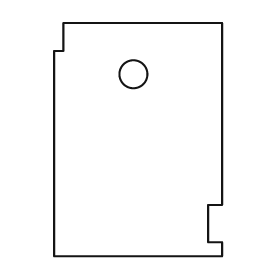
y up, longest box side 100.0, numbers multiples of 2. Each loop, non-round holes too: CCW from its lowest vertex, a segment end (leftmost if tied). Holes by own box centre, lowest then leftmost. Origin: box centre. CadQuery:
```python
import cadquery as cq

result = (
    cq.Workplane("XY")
    .moveTo(-36.0, -50.0)
    .lineTo(36.0, -50.0)
    .lineTo(36.0, -44.0)
    .lineTo(30.0, -44.0)
    .lineTo(30.0, -28.0)
    .lineTo(36.0, -28.0)
    .lineTo(36.0, 50.0)
    .lineTo(-32.0, 50.0)
    .lineTo(-32.0, 38.0)
    .lineTo(-36.0, 38.0)
    .close()
    .moveTo(-2.0, 28.0)
    .circle(6.0)
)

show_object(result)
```